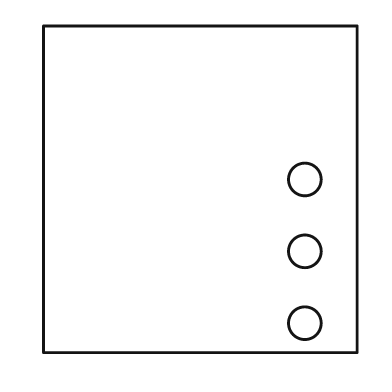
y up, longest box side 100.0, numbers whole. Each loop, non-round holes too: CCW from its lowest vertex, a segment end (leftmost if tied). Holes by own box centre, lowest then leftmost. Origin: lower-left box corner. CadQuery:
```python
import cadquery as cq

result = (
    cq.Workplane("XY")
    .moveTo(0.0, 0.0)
    .lineTo(96.0, 0.0)
    .lineTo(96.0, 100.0)
    .lineTo(0.0, 100.0)
    .close()
    .moveTo(80.0, 9.0)
    .circle(5.0)
    .moveTo(80.0, 31.0)
    .circle(5.0)
    .moveTo(80.0, 53.0)
    .circle(5.0)
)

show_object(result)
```